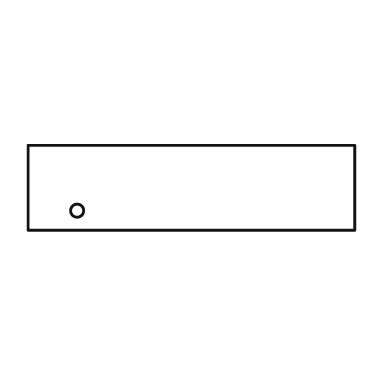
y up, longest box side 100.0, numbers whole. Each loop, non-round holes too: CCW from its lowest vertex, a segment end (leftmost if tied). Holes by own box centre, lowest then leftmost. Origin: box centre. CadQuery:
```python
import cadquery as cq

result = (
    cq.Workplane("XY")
    .moveTo(-50.0, -13.0)
    .lineTo(50.0, -13.0)
    .lineTo(50.0, 13.0)
    .lineTo(-50.0, 13.0)
    .close()
    .moveTo(-35.0, -7.0)
    .circle(2.0)
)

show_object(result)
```